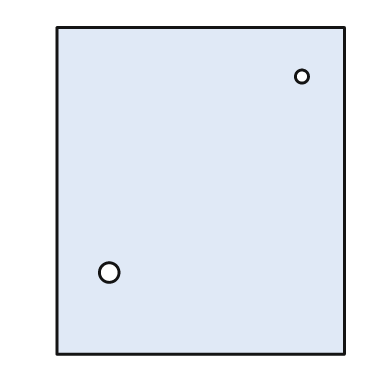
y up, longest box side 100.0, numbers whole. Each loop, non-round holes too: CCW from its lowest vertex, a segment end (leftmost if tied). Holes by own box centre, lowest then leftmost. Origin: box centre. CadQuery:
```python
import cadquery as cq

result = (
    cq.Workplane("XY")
    .moveTo(-44.0, -50.0)
    .lineTo(44.0, -50.0)
    .lineTo(44.0, 50.0)
    .lineTo(-44.0, 50.0)
    .close()
    .moveTo(-28.0, -25.0)
    .circle(3.0)
    .moveTo(31.0, 35.0)
    .circle(2.0)
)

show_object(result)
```